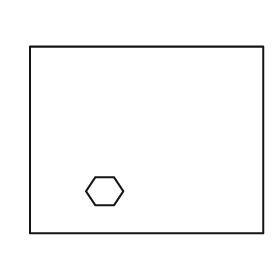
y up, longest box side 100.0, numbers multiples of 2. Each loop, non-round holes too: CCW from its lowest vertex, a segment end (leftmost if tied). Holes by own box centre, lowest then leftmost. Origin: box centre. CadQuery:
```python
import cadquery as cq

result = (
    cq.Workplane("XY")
    .moveTo(-50.0, -40.0)
    .lineTo(50.0, -40.0)
    .lineTo(50.0, 40.0)
    .lineTo(-50.0, 40.0)
    .close()
    .moveTo(-22.0, -28.0)
    .lineTo(-14.0, -28.0)
    .lineTo(-10.0, -22.0)
    .lineTo(-14.0, -16.0)
    .lineTo(-22.0, -16.0)
    .lineTo(-26.0, -22.0)
    .close()
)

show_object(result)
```